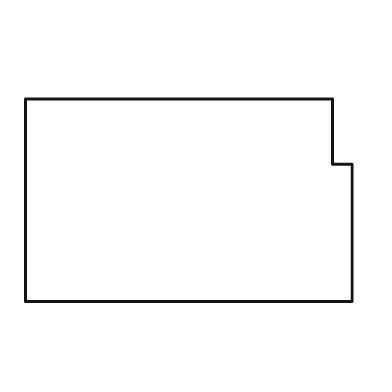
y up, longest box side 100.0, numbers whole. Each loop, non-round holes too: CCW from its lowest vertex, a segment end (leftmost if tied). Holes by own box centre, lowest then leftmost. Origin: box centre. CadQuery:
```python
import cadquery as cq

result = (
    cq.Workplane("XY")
    .moveTo(-50.0, -31.0)
    .lineTo(50.0, -31.0)
    .lineTo(50.0, 11.0)
    .lineTo(44.0, 11.0)
    .lineTo(44.0, 31.0)
    .lineTo(-50.0, 31.0)
    .close()
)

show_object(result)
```